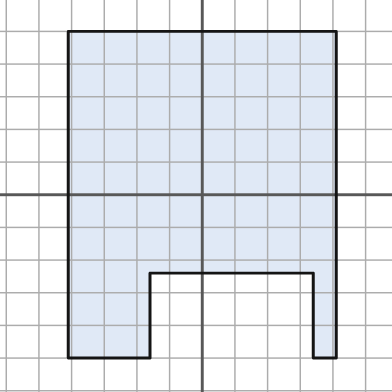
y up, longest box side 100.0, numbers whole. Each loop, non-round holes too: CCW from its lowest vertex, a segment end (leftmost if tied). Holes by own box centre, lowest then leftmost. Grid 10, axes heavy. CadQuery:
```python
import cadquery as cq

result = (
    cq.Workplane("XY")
    .moveTo(-41.0, -50.0)
    .lineTo(-16.0, -50.0)
    .lineTo(-16.0, -24.0)
    .lineTo(34.0, -24.0)
    .lineTo(34.0, -50.0)
    .lineTo(41.0, -50.0)
    .lineTo(41.0, 50.0)
    .lineTo(-41.0, 50.0)
    .close()
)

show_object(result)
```